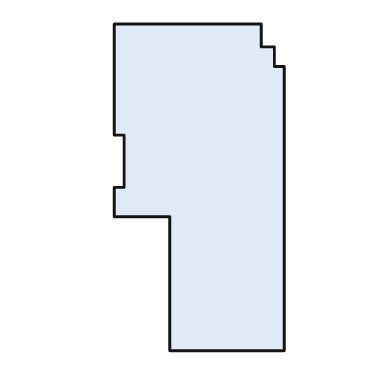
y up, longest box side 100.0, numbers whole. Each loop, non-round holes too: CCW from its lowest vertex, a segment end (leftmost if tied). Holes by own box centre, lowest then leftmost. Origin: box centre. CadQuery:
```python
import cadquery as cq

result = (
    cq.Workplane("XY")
    .moveTo(-9.0, -50.0)
    .lineTo(26.0, -50.0)
    .lineTo(26.0, 37.0)
    .lineTo(23.0, 37.0)
    .lineTo(23.0, 43.0)
    .lineTo(19.0, 43.0)
    .lineTo(19.0, 50.0)
    .lineTo(-26.0, 50.0)
    .lineTo(-26.0, 16.0)
    .lineTo(-23.0, 16.0)
    .lineTo(-23.0, 0.0)
    .lineTo(-26.0, 0.0)
    .lineTo(-26.0, -9.0)
    .lineTo(-9.0, -9.0)
    .close()
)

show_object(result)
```